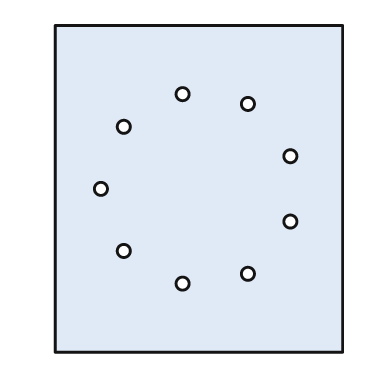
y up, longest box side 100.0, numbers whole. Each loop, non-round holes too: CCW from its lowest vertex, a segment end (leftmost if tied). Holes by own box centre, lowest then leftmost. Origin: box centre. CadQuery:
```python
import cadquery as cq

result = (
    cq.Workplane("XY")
    .moveTo(-44.0, -50.0)
    .lineTo(44.0, -50.0)
    .lineTo(44.0, 50.0)
    .lineTo(-44.0, 50.0)
    .close()
    .moveTo(-5.0, -29.0)
    .circle(2.0)
    .moveTo(15.0, -26.0)
    .circle(2.0)
    .moveTo(-23.0, -19.0)
    .circle(2.0)
    .moveTo(28.0, -10.0)
    .circle(2.0)
    .moveTo(-30.0, 0.0)
    .circle(2.0)
    .moveTo(28.0, 10.0)
    .circle(2.0)
    .moveTo(-23.0, 19.0)
    .circle(2.0)
    .moveTo(15.0, 26.0)
    .circle(2.0)
    .moveTo(-5.0, 29.0)
    .circle(2.0)
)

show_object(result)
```